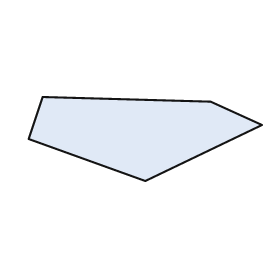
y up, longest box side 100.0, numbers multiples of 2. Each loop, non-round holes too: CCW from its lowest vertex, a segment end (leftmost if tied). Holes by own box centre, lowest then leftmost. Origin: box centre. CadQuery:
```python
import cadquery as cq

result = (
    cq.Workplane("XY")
    .moveTo(0.0, -18.0)
    .lineTo(50.0, 6.0)
    .lineTo(28.0, 16.0)
    .lineTo(-44.0, 18.0)
    .lineTo(-50.0, 0.0)
    .close()
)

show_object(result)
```